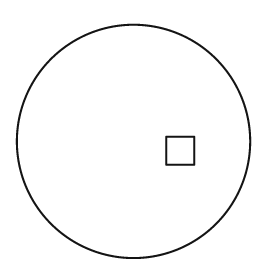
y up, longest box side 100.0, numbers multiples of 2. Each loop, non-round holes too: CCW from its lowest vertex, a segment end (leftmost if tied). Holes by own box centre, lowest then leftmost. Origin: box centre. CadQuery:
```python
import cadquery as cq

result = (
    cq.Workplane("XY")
    .moveTo(0.0, 0.0)
    .circle(50.0)
    .moveTo(14.0, -10.0)
    .lineTo(26.0, -10.0)
    .lineTo(26.0, 2.0)
    .lineTo(14.0, 2.0)
    .close()
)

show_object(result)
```